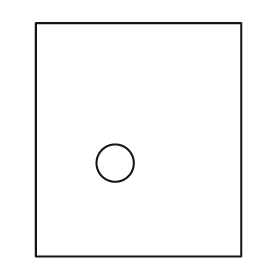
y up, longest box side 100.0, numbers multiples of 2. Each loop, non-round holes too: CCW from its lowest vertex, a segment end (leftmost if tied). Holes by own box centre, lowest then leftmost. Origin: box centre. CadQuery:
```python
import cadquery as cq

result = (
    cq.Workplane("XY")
    .moveTo(-44.0, -50.0)
    .lineTo(44.0, -50.0)
    .lineTo(44.0, 50.0)
    .lineTo(-44.0, 50.0)
    .close()
    .moveTo(-10.0, -10.0)
    .circle(8.0)
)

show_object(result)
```